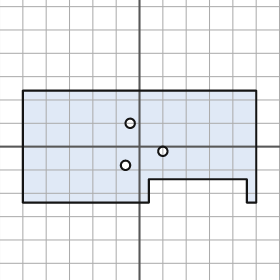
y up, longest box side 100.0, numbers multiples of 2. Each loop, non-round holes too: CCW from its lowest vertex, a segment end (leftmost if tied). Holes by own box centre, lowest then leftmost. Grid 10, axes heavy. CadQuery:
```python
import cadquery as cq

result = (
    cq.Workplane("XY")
    .moveTo(-50.0, -24.0)
    .lineTo(4.0, -24.0)
    .lineTo(4.0, -14.0)
    .lineTo(46.0, -14.0)
    .lineTo(46.0, -24.0)
    .lineTo(50.0, -24.0)
    .lineTo(50.0, 24.0)
    .lineTo(-50.0, 24.0)
    .close()
    .moveTo(-6.0, -8.0)
    .circle(2.0)
    .moveTo(10.0, -2.0)
    .circle(2.0)
    .moveTo(-4.0, 10.0)
    .circle(2.0)
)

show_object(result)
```